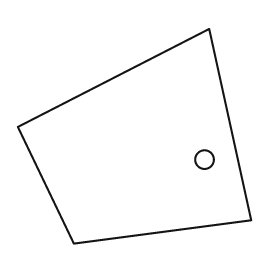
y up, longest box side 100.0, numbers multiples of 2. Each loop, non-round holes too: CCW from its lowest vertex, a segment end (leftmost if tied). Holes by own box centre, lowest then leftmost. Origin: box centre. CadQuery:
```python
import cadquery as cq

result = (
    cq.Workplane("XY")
    .moveTo(-26.0, -46.0)
    .lineTo(50.0, -36.0)
    .lineTo(32.0, 46.0)
    .lineTo(-50.0, 4.0)
    .close()
    .moveTo(30.0, -10.0)
    .circle(4.0)
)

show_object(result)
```